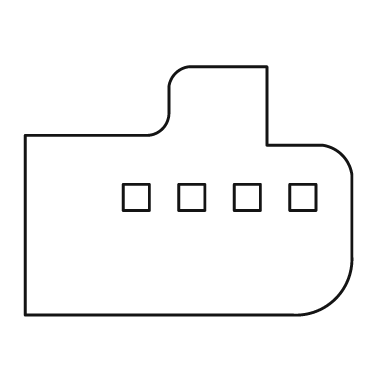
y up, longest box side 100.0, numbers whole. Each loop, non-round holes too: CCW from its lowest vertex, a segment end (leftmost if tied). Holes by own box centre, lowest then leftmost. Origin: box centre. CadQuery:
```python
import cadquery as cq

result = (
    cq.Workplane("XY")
    .moveTo(-50.0, -38.0)
    .lineTo(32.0, -38.0)
    .threePointArc((45.0, -33.0), (50.0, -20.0))
    .lineTo(50.0, 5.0)
    .threePointArc((47.0, 11.0), (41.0, 14.0))
    .lineTo(24.0, 14.0)
    .lineTo(24.0, 38.0)
    .lineTo(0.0, 38.0)
    .threePointArc((-4.0, 36.0), (-6.0, 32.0))
    .lineTo(-6.0, 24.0)
    .threePointArc((-8.0, 19.0), (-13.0, 17.0))
    .lineTo(-50.0, 17.0)
    .close()
    .moveTo(-20.0, -6.0)
    .lineTo(-12.0, -6.0)
    .lineTo(-12.0, 2.0)
    .lineTo(-20.0, 2.0)
    .close()
    .moveTo(-3.0, -6.0)
    .lineTo(5.0, -6.0)
    .lineTo(5.0, 2.0)
    .lineTo(-3.0, 2.0)
    .close()
    .moveTo(14.0, -6.0)
    .lineTo(22.0, -6.0)
    .lineTo(22.0, 2.0)
    .lineTo(14.0, 2.0)
    .close()
    .moveTo(31.0, -6.0)
    .lineTo(39.0, -6.0)
    .lineTo(39.0, 2.0)
    .lineTo(31.0, 2.0)
    .close()
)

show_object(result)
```